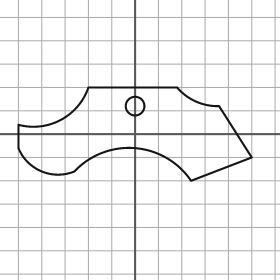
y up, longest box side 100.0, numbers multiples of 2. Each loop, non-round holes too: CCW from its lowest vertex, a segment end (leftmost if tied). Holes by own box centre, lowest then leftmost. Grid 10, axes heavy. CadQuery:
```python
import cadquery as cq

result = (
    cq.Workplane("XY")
    .moveTo(24.0, -20.0)
    .lineTo(50.0, -10.0)
    .lineTo(36.0, 12.0)
    .threePointArc((26.0, 14.0), (18.0, 20.0))
    .lineTo(-20.0, 20.0)
    .threePointArc((-32.0, 6.0), (-50.0, 4.0))
    .lineTo(-50.0, -6.0)
    .threePointArc((-40.0, -16.0), (-26.0, -16.0))
    .threePointArc((0.0, -6.0), (24.0, -20.0))
    .close()
    .moveTo(0.0, 12.0)
    .circle(4.0)
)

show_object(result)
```